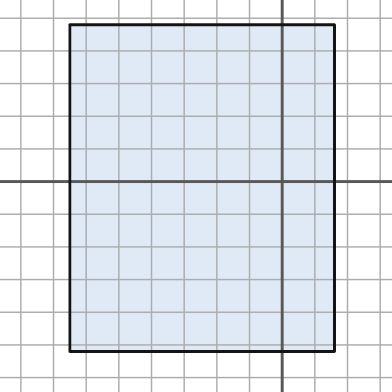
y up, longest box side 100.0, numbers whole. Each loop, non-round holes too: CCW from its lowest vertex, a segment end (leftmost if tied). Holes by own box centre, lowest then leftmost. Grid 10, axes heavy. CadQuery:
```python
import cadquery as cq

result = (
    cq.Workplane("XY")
    .moveTo(-65.0, -52.0)
    .lineTo(16.0, -52.0)
    .lineTo(16.0, 48.0)
    .lineTo(-65.0, 48.0)
    .close()
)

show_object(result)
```